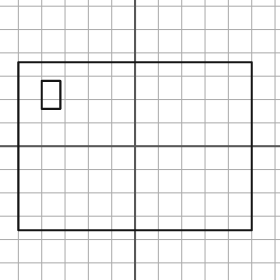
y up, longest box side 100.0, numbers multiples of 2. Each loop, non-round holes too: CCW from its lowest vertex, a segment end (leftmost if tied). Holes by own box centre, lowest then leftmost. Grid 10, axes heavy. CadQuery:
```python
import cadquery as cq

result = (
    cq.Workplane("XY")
    .moveTo(-50.0, -36.0)
    .lineTo(50.0, -36.0)
    .lineTo(50.0, 36.0)
    .lineTo(-50.0, 36.0)
    .close()
    .moveTo(-40.0, 16.0)
    .lineTo(-32.0, 16.0)
    .lineTo(-32.0, 28.0)
    .lineTo(-40.0, 28.0)
    .close()
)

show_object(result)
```